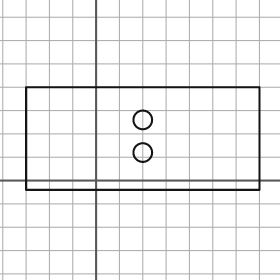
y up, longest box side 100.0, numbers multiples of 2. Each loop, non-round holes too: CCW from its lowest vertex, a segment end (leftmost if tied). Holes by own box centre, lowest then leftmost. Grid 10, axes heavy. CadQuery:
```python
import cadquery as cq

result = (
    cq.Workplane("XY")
    .moveTo(-30.0, -4.0)
    .lineTo(70.0, -4.0)
    .lineTo(70.0, 40.0)
    .lineTo(-30.0, 40.0)
    .close()
    .moveTo(20.0, 12.0)
    .circle(4.0)
    .moveTo(20.0, 26.0)
    .circle(4.0)
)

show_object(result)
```